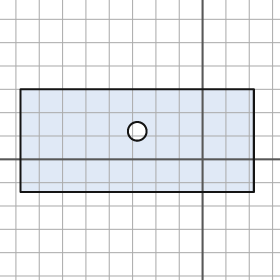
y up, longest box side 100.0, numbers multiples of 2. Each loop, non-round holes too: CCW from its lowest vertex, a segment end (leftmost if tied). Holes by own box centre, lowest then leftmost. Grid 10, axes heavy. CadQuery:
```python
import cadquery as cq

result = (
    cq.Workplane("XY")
    .moveTo(-78.0, -14.0)
    .lineTo(22.0, -14.0)
    .lineTo(22.0, 30.0)
    .lineTo(-78.0, 30.0)
    .close()
    .moveTo(-28.0, 12.0)
    .circle(4.0)
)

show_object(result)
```